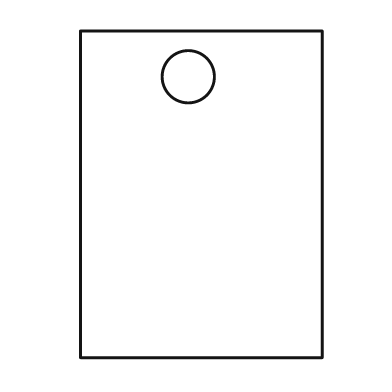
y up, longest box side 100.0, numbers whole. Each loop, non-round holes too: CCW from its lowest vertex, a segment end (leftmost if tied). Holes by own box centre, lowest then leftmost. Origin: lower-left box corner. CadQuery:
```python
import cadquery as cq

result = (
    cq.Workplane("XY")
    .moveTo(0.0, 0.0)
    .lineTo(74.0, 0.0)
    .lineTo(74.0, 100.0)
    .lineTo(0.0, 100.0)
    .close()
    .moveTo(33.0, 86.0)
    .circle(8.0)
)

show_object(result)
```